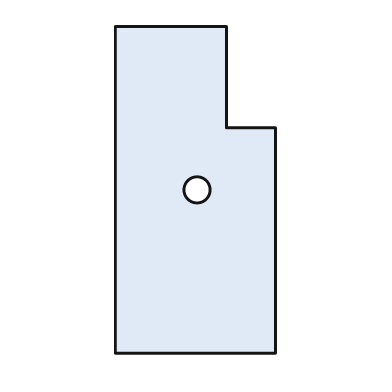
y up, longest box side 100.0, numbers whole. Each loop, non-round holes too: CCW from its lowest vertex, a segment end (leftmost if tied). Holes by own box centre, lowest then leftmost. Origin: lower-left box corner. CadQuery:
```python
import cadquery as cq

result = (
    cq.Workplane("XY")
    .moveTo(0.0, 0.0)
    .lineTo(49.0, 0.0)
    .lineTo(49.0, 69.0)
    .lineTo(34.0, 69.0)
    .lineTo(34.0, 100.0)
    .lineTo(0.0, 100.0)
    .close()
    .moveTo(25.0, 50.0)
    .circle(4.0)
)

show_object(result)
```